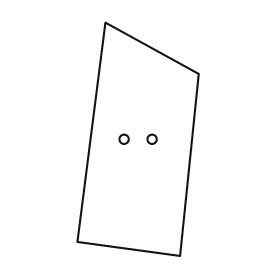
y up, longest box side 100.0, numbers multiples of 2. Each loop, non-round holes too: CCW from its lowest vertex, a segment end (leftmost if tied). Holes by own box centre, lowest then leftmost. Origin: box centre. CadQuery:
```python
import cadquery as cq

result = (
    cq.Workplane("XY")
    .moveTo(18.0, -50.0)
    .lineTo(26.0, 28.0)
    .lineTo(-14.0, 50.0)
    .lineTo(-26.0, -44.0)
    .close()
    .moveTo(-6.0, 0.0)
    .circle(2.0)
    .moveTo(6.0, 0.0)
    .circle(2.0)
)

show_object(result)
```